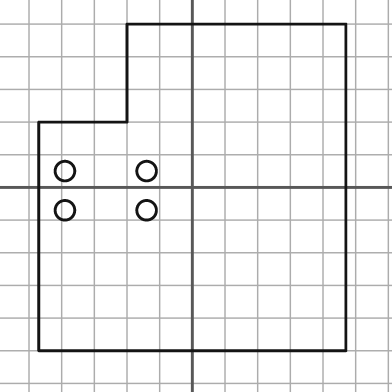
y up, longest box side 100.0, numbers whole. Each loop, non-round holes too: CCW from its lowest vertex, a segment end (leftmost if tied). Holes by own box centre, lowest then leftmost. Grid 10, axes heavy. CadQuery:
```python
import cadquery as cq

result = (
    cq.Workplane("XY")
    .moveTo(-47.0, -50.0)
    .lineTo(47.0, -50.0)
    .lineTo(47.0, 50.0)
    .lineTo(-20.0, 50.0)
    .lineTo(-20.0, 20.0)
    .lineTo(-47.0, 20.0)
    .close()
    .moveTo(-39.0, -7.0)
    .circle(3.0)
    .moveTo(-14.0, -7.0)
    .circle(3.0)
    .moveTo(-39.0, 5.0)
    .circle(3.0)
    .moveTo(-14.0, 5.0)
    .circle(3.0)
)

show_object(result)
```